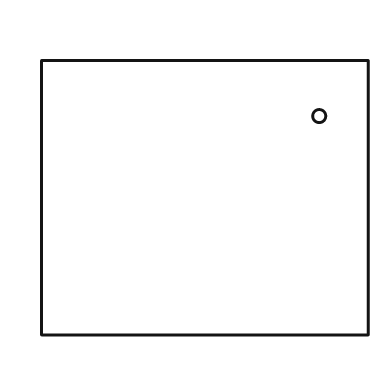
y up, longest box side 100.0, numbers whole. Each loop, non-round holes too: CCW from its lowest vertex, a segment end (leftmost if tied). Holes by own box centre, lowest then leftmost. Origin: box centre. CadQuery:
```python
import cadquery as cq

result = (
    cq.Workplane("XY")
    .moveTo(-50.0, -42.0)
    .lineTo(50.0, -42.0)
    .lineTo(50.0, 42.0)
    .lineTo(-50.0, 42.0)
    .close()
    .moveTo(35.0, 25.0)
    .circle(2.0)
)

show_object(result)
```